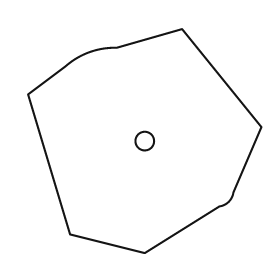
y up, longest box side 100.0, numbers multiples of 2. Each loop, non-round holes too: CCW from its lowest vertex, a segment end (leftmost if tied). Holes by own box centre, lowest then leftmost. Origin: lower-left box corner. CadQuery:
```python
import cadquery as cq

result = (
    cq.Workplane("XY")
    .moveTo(50.0, 0.0)
    .lineTo(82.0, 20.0)
    .threePointArc((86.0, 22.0), (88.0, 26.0))
    .lineTo(100.0, 54.0)
    .lineTo(66.0, 96.0)
    .lineTo(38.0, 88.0)
    .threePointArc((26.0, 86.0), (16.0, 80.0))
    .lineTo(0.0, 68.0)
    .lineTo(18.0, 8.0)
    .close()
    .moveTo(50.0, 48.0)
    .circle(4.0)
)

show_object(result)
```